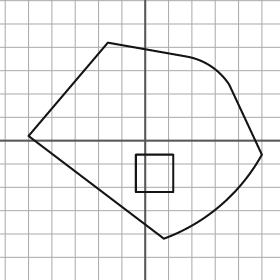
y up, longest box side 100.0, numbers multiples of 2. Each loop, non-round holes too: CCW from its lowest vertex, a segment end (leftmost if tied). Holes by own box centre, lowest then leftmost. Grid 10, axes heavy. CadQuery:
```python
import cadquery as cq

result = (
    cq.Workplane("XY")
    .moveTo(8.0, -42.0)
    .threePointArc((32.0, -28.0), (50.0, -6.0))
    .lineTo(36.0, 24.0)
    .threePointArc((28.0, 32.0), (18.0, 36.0))
    .lineTo(-16.0, 42.0)
    .lineTo(-50.0, 2.0)
    .close()
    .moveTo(-4.0, -22.0)
    .lineTo(12.0, -22.0)
    .lineTo(12.0, -6.0)
    .lineTo(-4.0, -6.0)
    .close()
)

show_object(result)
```